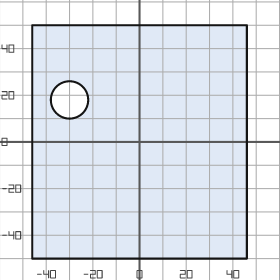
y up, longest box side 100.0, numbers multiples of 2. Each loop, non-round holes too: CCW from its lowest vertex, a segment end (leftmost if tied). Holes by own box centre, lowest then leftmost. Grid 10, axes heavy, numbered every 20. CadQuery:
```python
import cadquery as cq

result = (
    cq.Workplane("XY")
    .moveTo(-46.0, -50.0)
    .lineTo(46.0, -50.0)
    .lineTo(46.0, 50.0)
    .lineTo(-46.0, 50.0)
    .close()
    .moveTo(-30.0, 18.0)
    .circle(8.0)
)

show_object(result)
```